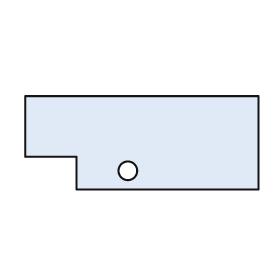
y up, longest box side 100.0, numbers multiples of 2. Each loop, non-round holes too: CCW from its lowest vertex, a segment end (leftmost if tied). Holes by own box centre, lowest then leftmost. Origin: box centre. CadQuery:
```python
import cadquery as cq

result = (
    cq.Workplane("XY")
    .moveTo(-28.0, -20.0)
    .lineTo(50.0, -20.0)
    .lineTo(50.0, 20.0)
    .lineTo(-50.0, 20.0)
    .lineTo(-50.0, -6.0)
    .lineTo(-28.0, -6.0)
    .close()
    .moveTo(-6.0, -12.0)
    .circle(4.0)
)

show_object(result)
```